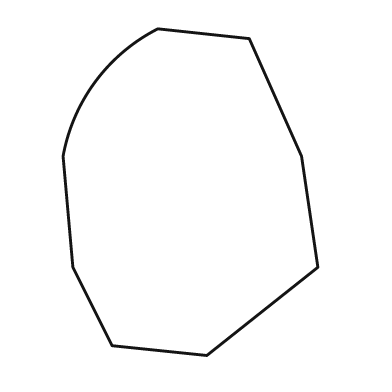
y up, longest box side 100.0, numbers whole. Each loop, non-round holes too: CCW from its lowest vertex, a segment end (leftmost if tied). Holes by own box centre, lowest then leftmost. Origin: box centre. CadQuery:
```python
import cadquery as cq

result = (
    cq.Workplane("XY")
    .moveTo(5.0, -50.0)
    .lineTo(39.0, -23.0)
    .lineTo(34.0, 11.0)
    .lineTo(18.0, 47.0)
    .lineTo(-10.0, 50.0)
    .threePointArc((-29.0, 34.0), (-39.0, 11.0))
    .lineTo(-36.0, -23.0)
    .lineTo(-24.0, -47.0)
    .close()
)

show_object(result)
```